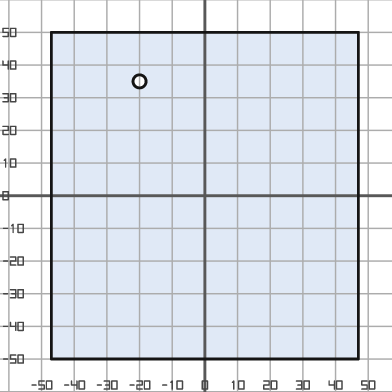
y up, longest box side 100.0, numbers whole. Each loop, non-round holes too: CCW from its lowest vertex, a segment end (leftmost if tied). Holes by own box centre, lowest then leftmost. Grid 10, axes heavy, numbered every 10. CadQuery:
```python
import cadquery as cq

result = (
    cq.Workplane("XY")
    .moveTo(-47.0, -50.0)
    .lineTo(47.0, -50.0)
    .lineTo(47.0, 50.0)
    .lineTo(-47.0, 50.0)
    .close()
    .moveTo(-20.0, 35.0)
    .circle(2.0)
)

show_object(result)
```